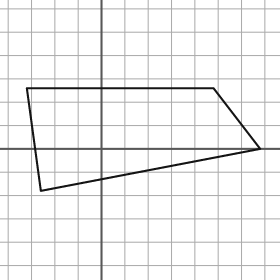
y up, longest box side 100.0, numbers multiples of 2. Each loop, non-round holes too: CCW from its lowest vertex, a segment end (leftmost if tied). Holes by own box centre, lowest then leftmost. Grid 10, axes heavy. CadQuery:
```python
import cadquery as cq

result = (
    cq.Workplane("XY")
    .moveTo(-26.0, -18.0)
    .lineTo(68.0, 0.0)
    .lineTo(48.0, 26.0)
    .lineTo(-32.0, 26.0)
    .close()
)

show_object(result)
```